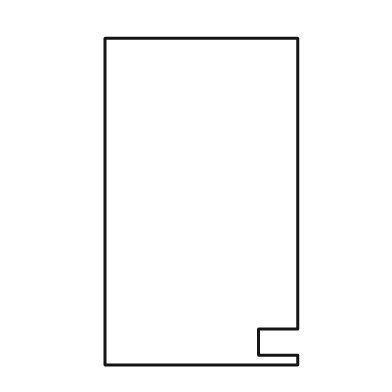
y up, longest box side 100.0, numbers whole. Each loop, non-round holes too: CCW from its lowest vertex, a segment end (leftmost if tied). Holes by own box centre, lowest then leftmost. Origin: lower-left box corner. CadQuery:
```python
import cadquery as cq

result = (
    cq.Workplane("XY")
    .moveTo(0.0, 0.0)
    .lineTo(59.0, 0.0)
    .lineTo(59.0, 3.0)
    .lineTo(47.0, 3.0)
    .lineTo(47.0, 11.0)
    .lineTo(59.0, 11.0)
    .lineTo(59.0, 100.0)
    .lineTo(0.0, 100.0)
    .close()
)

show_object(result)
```